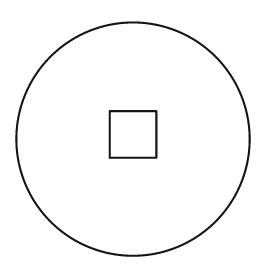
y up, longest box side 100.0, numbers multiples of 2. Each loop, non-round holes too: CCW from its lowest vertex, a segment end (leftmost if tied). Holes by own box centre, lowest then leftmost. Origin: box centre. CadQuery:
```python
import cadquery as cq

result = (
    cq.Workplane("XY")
    .moveTo(0.0, 0.0)
    .circle(50.0)
    .moveTo(-10.0, -8.0)
    .lineTo(10.0, -8.0)
    .lineTo(10.0, 12.0)
    .lineTo(-10.0, 12.0)
    .close()
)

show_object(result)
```